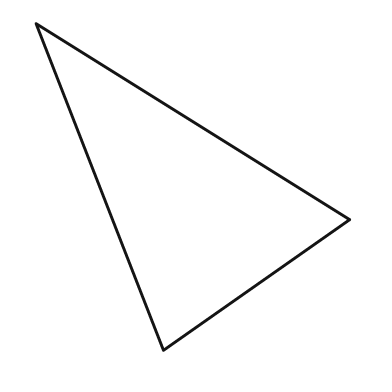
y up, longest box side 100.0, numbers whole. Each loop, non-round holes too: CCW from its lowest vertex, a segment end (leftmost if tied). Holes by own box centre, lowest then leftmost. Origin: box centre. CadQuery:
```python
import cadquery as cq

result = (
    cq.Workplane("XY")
    .moveTo(-9.0, -50.0)
    .lineTo(48.0, -10.0)
    .lineTo(-48.0, 50.0)
    .close()
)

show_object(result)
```